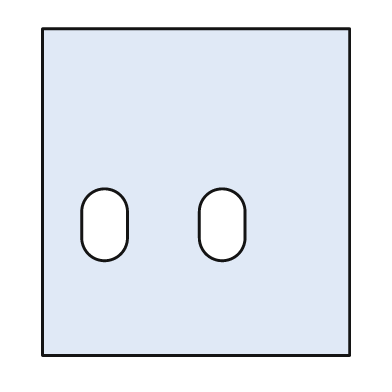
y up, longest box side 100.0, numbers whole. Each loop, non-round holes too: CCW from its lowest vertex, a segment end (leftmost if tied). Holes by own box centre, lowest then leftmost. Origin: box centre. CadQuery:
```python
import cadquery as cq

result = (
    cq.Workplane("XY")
    .moveTo(-47.0, -50.0)
    .lineTo(47.0, -50.0)
    .lineTo(47.0, 50.0)
    .lineTo(-47.0, 50.0)
    .close()
    .moveTo(-35.0, -14.0)
    .threePointArc((-28.0, -21.0), (-21.0, -14.0))
    .lineTo(-21.0, -6.0)
    .threePointArc((-28.0, 1.0), (-35.0, -6.0))
    .close()
    .moveTo(1.0, -14.0)
    .threePointArc((8.0, -21.0), (15.0, -14.0))
    .lineTo(15.0, -6.0)
    .threePointArc((8.0, 1.0), (1.0, -6.0))
    .close()
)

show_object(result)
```